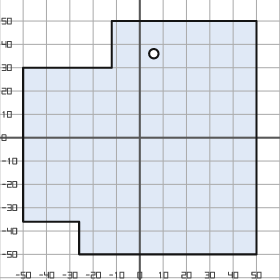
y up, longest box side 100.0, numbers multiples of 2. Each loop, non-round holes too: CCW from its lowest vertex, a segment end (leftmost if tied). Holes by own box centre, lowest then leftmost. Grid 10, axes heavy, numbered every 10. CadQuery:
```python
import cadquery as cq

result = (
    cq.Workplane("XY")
    .moveTo(-26.0, -50.0)
    .lineTo(50.0, -50.0)
    .lineTo(50.0, 50.0)
    .lineTo(-12.0, 50.0)
    .lineTo(-12.0, 30.0)
    .lineTo(-50.0, 30.0)
    .lineTo(-50.0, -36.0)
    .lineTo(-26.0, -36.0)
    .close()
    .moveTo(6.0, 36.0)
    .circle(2.0)
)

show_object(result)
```